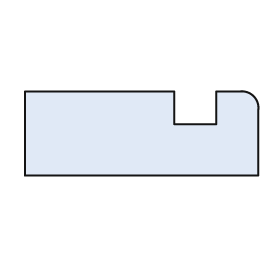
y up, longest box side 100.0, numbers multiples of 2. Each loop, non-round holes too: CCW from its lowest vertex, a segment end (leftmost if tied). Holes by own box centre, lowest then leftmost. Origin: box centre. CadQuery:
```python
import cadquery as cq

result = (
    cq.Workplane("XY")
    .moveTo(-50.0, -18.0)
    .lineTo(50.0, -18.0)
    .lineTo(50.0, 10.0)
    .threePointArc((48.0, 16.0), (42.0, 18.0))
    .lineTo(32.0, 18.0)
    .lineTo(32.0, 4.0)
    .lineTo(14.0, 4.0)
    .lineTo(14.0, 18.0)
    .lineTo(-50.0, 18.0)
    .close()
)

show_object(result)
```